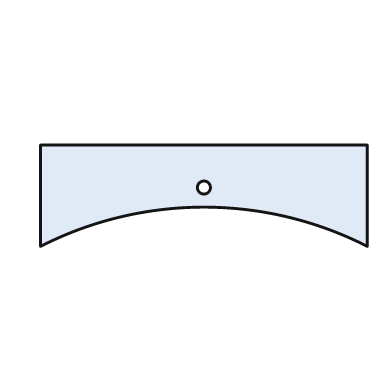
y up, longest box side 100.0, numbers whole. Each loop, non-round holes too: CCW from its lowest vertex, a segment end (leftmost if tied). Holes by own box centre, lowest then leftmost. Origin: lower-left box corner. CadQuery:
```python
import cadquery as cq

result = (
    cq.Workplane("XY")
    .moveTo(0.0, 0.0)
    .threePointArc((50.0, 12.0), (100.0, 0.0))
    .lineTo(100.0, 31.0)
    .lineTo(0.0, 31.0)
    .close()
    .moveTo(50.0, 18.0)
    .circle(2.0)
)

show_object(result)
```